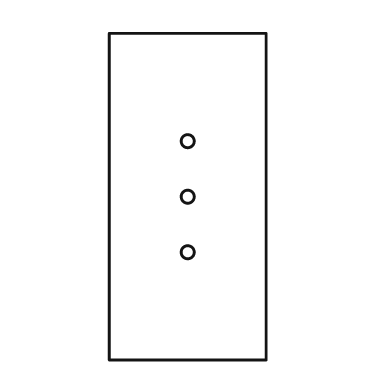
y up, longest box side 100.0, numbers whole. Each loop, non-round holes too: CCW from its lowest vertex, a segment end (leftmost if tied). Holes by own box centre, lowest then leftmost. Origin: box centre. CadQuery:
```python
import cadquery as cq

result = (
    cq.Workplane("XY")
    .moveTo(-24.0, -50.0)
    .lineTo(24.0, -50.0)
    .lineTo(24.0, 50.0)
    .lineTo(-24.0, 50.0)
    .close()
    .moveTo(0.0, -17.0)
    .circle(2.0)
    .moveTo(0.0, 0.0)
    .circle(2.0)
    .moveTo(0.0, 17.0)
    .circle(2.0)
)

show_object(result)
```